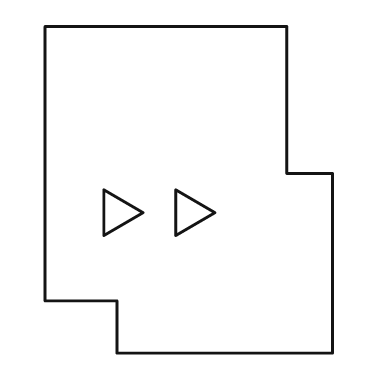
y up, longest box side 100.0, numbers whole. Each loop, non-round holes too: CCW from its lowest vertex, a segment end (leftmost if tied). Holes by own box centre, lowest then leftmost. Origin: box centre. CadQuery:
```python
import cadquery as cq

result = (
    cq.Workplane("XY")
    .moveTo(-22.0, -50.0)
    .lineTo(44.0, -50.0)
    .lineTo(44.0, 5.0)
    .lineTo(30.0, 5.0)
    .lineTo(30.0, 50.0)
    .lineTo(-44.0, 50.0)
    .lineTo(-44.0, -34.0)
    .lineTo(-22.0, -34.0)
    .close()
    .moveTo(-26.0, -14.0)
    .lineTo(-14.0, -7.0)
    .lineTo(-26.0, 0.0)
    .close()
    .moveTo(-4.0, -14.0)
    .lineTo(8.0, -7.0)
    .lineTo(-4.0, 0.0)
    .close()
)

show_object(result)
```